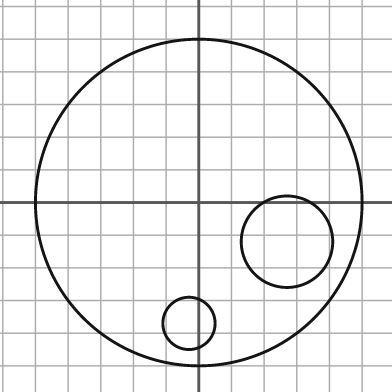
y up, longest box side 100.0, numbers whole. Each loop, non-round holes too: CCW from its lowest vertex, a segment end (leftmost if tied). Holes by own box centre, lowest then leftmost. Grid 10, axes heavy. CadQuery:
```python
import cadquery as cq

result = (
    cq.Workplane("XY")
    .moveTo(0.0, 0.0)
    .circle(50.0)
    .moveTo(-3.0, -37.0)
    .circle(8.0)
    .moveTo(27.0, -12.0)
    .circle(14.0)
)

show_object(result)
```